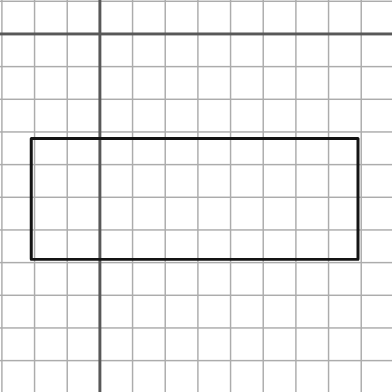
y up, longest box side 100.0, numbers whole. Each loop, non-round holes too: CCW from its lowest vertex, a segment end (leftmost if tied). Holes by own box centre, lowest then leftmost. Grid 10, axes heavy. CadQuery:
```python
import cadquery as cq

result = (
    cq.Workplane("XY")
    .moveTo(-21.0, -69.0)
    .lineTo(79.0, -69.0)
    .lineTo(79.0, -32.0)
    .lineTo(-21.0, -32.0)
    .close()
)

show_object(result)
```